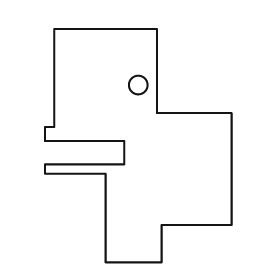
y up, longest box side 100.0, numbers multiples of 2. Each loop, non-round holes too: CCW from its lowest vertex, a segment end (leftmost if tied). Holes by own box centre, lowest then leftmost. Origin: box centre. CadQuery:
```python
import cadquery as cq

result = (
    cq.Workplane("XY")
    .moveTo(-14.0, -50.0)
    .lineTo(10.0, -50.0)
    .lineTo(10.0, -34.0)
    .lineTo(40.0, -34.0)
    .lineTo(40.0, 14.0)
    .lineTo(8.0, 14.0)
    .lineTo(8.0, 50.0)
    .lineTo(-36.0, 50.0)
    .lineTo(-36.0, 8.0)
    .lineTo(-40.0, 8.0)
    .lineTo(-40.0, 2.0)
    .lineTo(-6.0, 2.0)
    .lineTo(-6.0, -8.0)
    .lineTo(-40.0, -8.0)
    .lineTo(-40.0, -12.0)
    .lineTo(-14.0, -12.0)
    .close()
    .moveTo(0.0, 26.0)
    .circle(4.0)
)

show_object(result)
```